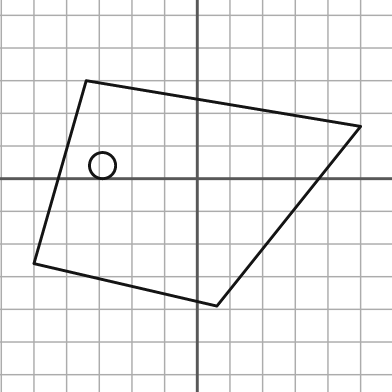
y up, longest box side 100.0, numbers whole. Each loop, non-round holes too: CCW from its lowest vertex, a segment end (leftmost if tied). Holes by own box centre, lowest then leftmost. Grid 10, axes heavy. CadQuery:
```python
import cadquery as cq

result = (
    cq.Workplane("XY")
    .moveTo(6.0, -39.0)
    .lineTo(50.0, 16.0)
    .lineTo(-34.0, 30.0)
    .lineTo(-50.0, -26.0)
    .close()
    .moveTo(-29.0, 4.0)
    .circle(4.0)
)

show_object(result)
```